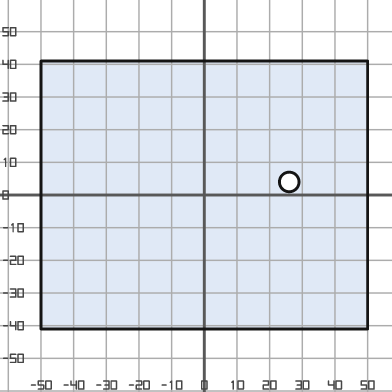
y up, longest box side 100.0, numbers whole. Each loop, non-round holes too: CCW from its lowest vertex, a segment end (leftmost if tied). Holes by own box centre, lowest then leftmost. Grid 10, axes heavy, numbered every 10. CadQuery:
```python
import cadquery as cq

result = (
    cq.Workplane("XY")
    .moveTo(-50.0, -41.0)
    .lineTo(50.0, -41.0)
    .lineTo(50.0, 41.0)
    .lineTo(-50.0, 41.0)
    .close()
    .moveTo(26.0, 4.0)
    .circle(3.0)
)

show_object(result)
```